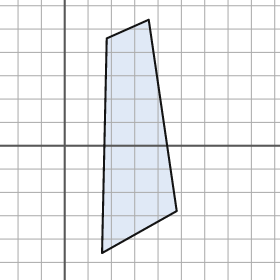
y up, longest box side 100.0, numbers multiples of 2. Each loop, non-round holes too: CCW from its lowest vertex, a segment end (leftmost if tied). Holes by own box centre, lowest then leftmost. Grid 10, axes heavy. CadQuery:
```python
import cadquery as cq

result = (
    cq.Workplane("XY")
    .moveTo(16.0, -46.0)
    .lineTo(48.0, -28.0)
    .lineTo(36.0, 54.0)
    .lineTo(18.0, 46.0)
    .close()
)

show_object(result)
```